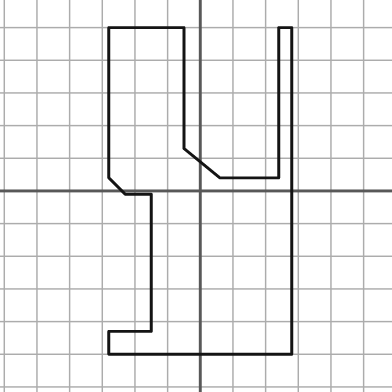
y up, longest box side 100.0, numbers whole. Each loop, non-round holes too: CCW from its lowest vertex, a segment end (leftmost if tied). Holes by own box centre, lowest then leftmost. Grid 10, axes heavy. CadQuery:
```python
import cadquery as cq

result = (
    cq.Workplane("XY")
    .moveTo(-28.0, -50.0)
    .lineTo(28.0, -50.0)
    .lineTo(28.0, 50.0)
    .lineTo(24.0, 50.0)
    .lineTo(24.0, 4.0)
    .lineTo(6.0, 4.0)
    .lineTo(-5.0, 13.0)
    .lineTo(-5.0, 50.0)
    .lineTo(-28.0, 50.0)
    .lineTo(-28.0, 4.0)
    .lineTo(-23.0, -1.0)
    .lineTo(-15.0, -1.0)
    .lineTo(-15.0, -43.0)
    .lineTo(-28.0, -43.0)
    .close()
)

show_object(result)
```